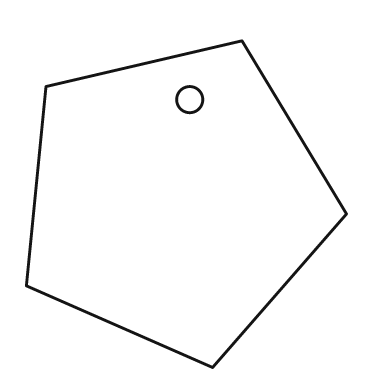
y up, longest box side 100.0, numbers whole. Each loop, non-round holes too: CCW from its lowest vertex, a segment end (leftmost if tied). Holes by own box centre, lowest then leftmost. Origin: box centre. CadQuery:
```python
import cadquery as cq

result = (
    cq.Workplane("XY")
    .moveTo(8.0, -50.0)
    .lineTo(49.0, -3.0)
    .lineTo(17.0, 50.0)
    .lineTo(-43.0, 36.0)
    .lineTo(-49.0, -25.0)
    .close()
    .moveTo(1.0, 32.0)
    .circle(4.0)
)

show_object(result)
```